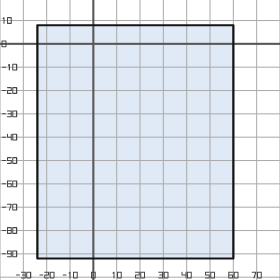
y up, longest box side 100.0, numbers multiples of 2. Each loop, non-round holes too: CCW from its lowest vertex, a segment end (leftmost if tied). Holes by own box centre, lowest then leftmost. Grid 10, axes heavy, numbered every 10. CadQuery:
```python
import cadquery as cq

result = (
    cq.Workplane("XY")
    .moveTo(-24.0, -92.0)
    .lineTo(60.0, -92.0)
    .lineTo(60.0, 8.0)
    .lineTo(-24.0, 8.0)
    .close()
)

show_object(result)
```